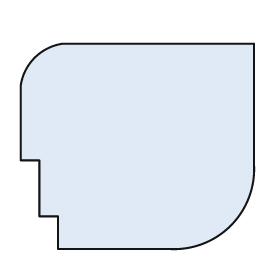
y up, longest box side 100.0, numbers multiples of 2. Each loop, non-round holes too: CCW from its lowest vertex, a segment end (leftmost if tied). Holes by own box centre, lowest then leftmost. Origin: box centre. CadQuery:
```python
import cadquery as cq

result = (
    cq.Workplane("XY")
    .moveTo(-34.0, -44.0)
    .lineTo(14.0, -44.0)
    .threePointArc((40.0, -34.0), (50.0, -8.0))
    .lineTo(50.0, 44.0)
    .lineTo(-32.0, 44.0)
    .threePointArc((-44.0, 38.0), (-50.0, 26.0))
    .lineTo(-50.0, -6.0)
    .lineTo(-42.0, -6.0)
    .lineTo(-42.0, -30.0)
    .lineTo(-34.0, -30.0)
    .close()
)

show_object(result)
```